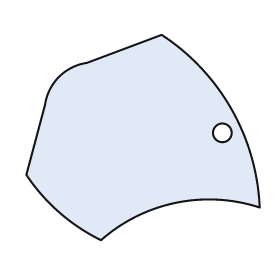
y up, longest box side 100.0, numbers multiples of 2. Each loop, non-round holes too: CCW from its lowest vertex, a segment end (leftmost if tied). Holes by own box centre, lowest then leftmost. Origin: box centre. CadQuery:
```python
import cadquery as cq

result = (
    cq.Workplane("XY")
    .moveTo(-18.0, -44.0)
    .threePointArc((14.0, -28.0), (50.0, -30.0))
    .threePointArc((38.0, 12.0), (8.0, 44.0))
    .lineTo(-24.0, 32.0)
    .threePointArc((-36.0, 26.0), (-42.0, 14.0))
    .lineTo(-50.0, -16.0)
    .threePointArc((-36.0, -32.0), (-18.0, -44.0))
    .close()
    .moveTo(34.0, 2.0)
    .circle(4.0)
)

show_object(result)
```